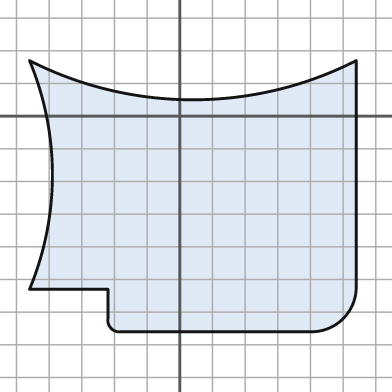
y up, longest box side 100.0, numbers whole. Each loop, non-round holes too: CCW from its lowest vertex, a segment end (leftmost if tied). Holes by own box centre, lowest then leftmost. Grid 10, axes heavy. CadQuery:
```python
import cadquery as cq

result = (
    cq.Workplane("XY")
    .moveTo(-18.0, -66.0)
    .lineTo(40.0, -66.0)
    .threePointArc((50.0, -62.0), (54.0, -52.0))
    .lineTo(54.0, 17.0)
    .threePointArc((4.0, 5.0), (-46.0, 17.0))
    .threePointArc((-39.0, -18.0), (-46.0, -53.0))
    .lineTo(-22.0, -53.0)
    .lineTo(-22.0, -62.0)
    .threePointArc((-21.0, -65.0), (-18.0, -66.0))
    .close()
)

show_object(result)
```